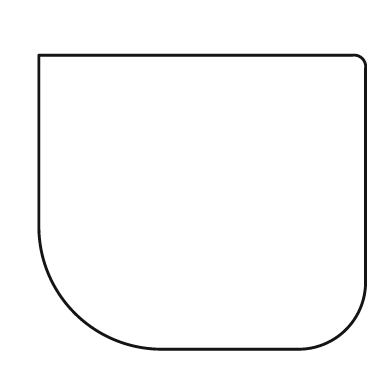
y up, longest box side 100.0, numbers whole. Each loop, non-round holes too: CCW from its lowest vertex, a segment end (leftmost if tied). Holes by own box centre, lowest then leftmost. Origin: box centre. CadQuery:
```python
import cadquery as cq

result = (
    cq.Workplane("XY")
    .moveTo(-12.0, -45.0)
    .lineTo(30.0, -45.0)
    .threePointArc((44.0, -39.0), (50.0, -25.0))
    .lineTo(50.0, 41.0)
    .threePointArc((49.0, 44.0), (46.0, 45.0))
    .lineTo(-50.0, 45.0)
    .lineTo(-50.0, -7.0)
    .threePointArc((-39.0, -34.0), (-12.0, -45.0))
    .close()
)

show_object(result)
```